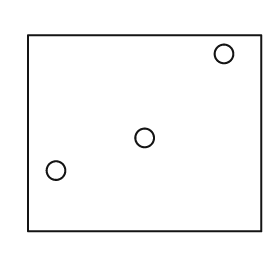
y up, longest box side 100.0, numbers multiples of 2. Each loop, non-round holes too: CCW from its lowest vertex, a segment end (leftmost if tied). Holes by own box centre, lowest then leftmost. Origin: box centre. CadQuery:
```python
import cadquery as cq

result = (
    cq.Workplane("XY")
    .moveTo(-50.0, -42.0)
    .lineTo(50.0, -42.0)
    .lineTo(50.0, 42.0)
    .lineTo(-50.0, 42.0)
    .close()
    .moveTo(-38.0, -16.0)
    .circle(4.0)
    .moveTo(0.0, -2.0)
    .circle(4.0)
    .moveTo(34.0, 34.0)
    .circle(4.0)
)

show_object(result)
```